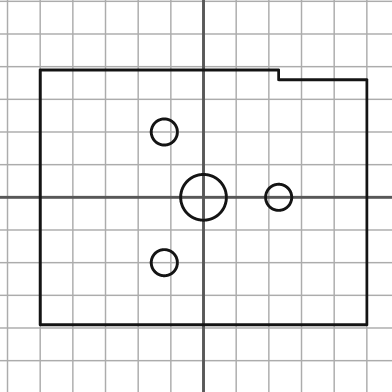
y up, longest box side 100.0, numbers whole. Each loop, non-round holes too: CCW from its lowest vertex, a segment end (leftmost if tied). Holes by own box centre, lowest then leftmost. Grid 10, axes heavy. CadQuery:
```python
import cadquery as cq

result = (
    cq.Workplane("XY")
    .moveTo(-50.0, -39.0)
    .lineTo(50.0, -39.0)
    .lineTo(50.0, 36.0)
    .lineTo(23.0, 36.0)
    .lineTo(23.0, 39.0)
    .lineTo(-50.0, 39.0)
    .close()
    .moveTo(-12.0, -20.0)
    .circle(4.0)
    .moveTo(0.0, 0.0)
    .circle(7.0)
    .moveTo(23.0, 0.0)
    .circle(4.0)
    .moveTo(-12.0, 20.0)
    .circle(4.0)
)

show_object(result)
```